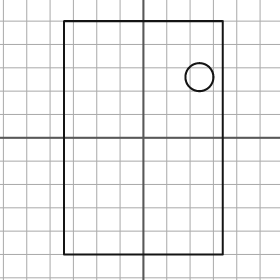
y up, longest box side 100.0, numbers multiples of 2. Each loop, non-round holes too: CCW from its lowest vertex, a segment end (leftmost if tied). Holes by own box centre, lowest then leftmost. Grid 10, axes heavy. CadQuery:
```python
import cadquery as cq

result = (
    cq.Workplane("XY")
    .moveTo(-34.0, -50.0)
    .lineTo(34.0, -50.0)
    .lineTo(34.0, 50.0)
    .lineTo(-34.0, 50.0)
    .close()
    .moveTo(24.0, 26.0)
    .circle(6.0)
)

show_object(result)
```